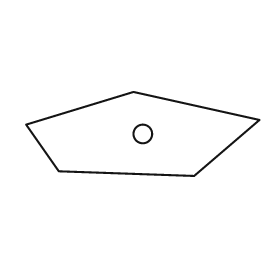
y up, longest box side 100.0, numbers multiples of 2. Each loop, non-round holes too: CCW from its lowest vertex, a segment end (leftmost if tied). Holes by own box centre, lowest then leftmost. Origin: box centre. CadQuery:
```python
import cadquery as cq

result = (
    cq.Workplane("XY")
    .moveTo(22.0, -18.0)
    .lineTo(50.0, 6.0)
    .lineTo(-4.0, 18.0)
    .lineTo(-50.0, 4.0)
    .lineTo(-36.0, -16.0)
    .close()
    .moveTo(0.0, 0.0)
    .circle(4.0)
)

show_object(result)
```